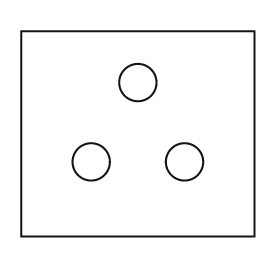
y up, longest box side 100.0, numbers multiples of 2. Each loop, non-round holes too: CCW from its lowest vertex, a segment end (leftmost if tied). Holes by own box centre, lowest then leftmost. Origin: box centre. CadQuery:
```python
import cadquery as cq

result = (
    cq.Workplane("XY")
    .moveTo(-50.0, -44.0)
    .lineTo(50.0, -44.0)
    .lineTo(50.0, 44.0)
    .lineTo(-50.0, 44.0)
    .close()
    .moveTo(-20.0, -12.0)
    .circle(8.0)
    .moveTo(20.0, -12.0)
    .circle(8.0)
    .moveTo(0.0, 22.0)
    .circle(8.0)
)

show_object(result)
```